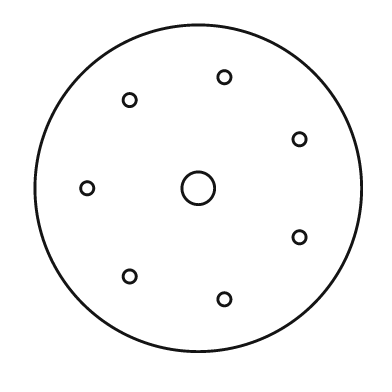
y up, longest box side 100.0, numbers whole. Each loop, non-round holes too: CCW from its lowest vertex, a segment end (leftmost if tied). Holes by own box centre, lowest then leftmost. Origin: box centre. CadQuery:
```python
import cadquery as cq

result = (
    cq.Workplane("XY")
    .moveTo(0.0, 0.0)
    .circle(50.0)
    .moveTo(8.0, -34.0)
    .circle(2.0)
    .moveTo(-21.0, -27.0)
    .circle(2.0)
    .moveTo(31.0, -15.0)
    .circle(2.0)
    .moveTo(-34.0, 0.0)
    .circle(2.0)
    .moveTo(0.0, 0.0)
    .circle(5.0)
    .moveTo(31.0, 15.0)
    .circle(2.0)
    .moveTo(-21.0, 27.0)
    .circle(2.0)
    .moveTo(8.0, 34.0)
    .circle(2.0)
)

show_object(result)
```